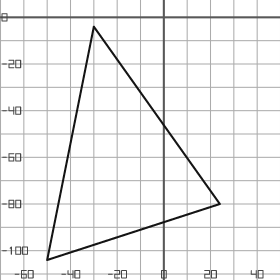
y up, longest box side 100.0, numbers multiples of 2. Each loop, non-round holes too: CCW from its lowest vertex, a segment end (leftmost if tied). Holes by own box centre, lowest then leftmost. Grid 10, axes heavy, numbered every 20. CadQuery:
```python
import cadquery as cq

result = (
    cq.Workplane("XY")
    .moveTo(-50.0, -104.0)
    .lineTo(24.0, -80.0)
    .lineTo(-30.0, -4.0)
    .close()
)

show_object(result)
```